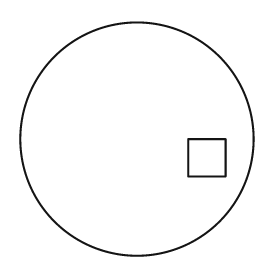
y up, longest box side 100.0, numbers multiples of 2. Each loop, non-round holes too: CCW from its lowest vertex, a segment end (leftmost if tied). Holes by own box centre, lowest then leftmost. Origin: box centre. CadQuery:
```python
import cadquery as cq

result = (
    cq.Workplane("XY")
    .moveTo(0.0, 0.0)
    .circle(50.0)
    .moveTo(22.0, -16.0)
    .lineTo(38.0, -16.0)
    .lineTo(38.0, 0.0)
    .lineTo(22.0, 0.0)
    .close()
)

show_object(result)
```